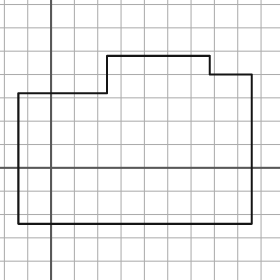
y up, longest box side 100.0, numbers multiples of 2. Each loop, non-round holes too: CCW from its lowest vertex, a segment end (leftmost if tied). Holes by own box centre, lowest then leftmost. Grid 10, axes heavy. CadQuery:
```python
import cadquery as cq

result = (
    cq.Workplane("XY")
    .moveTo(-14.0, -24.0)
    .lineTo(86.0, -24.0)
    .lineTo(86.0, 40.0)
    .lineTo(68.0, 40.0)
    .lineTo(68.0, 48.0)
    .lineTo(24.0, 48.0)
    .lineTo(24.0, 32.0)
    .lineTo(-14.0, 32.0)
    .close()
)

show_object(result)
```